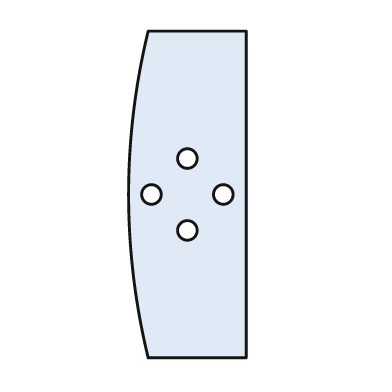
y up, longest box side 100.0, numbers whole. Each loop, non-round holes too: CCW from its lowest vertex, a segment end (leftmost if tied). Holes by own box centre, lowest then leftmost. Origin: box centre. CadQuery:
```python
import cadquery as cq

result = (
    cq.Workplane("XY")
    .moveTo(-12.0, -50.0)
    .lineTo(18.0, -50.0)
    .lineTo(18.0, 50.0)
    .lineTo(-12.0, 50.0)
    .threePointArc((-18.0, 0.0), (-12.0, -50.0))
    .close()
    .moveTo(0.0, -11.0)
    .circle(3.0)
    .moveTo(-11.0, 0.0)
    .circle(3.0)
    .moveTo(11.0, 0.0)
    .circle(3.0)
    .moveTo(0.0, 11.0)
    .circle(3.0)
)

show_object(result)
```